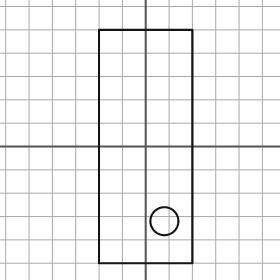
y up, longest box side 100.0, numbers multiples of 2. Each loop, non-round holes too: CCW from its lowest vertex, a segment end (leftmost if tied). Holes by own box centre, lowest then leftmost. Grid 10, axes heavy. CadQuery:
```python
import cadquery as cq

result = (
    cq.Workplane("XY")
    .moveTo(-20.0, -50.0)
    .lineTo(20.0, -50.0)
    .lineTo(20.0, 50.0)
    .lineTo(-20.0, 50.0)
    .close()
    .moveTo(8.0, -32.0)
    .circle(6.0)
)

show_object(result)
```